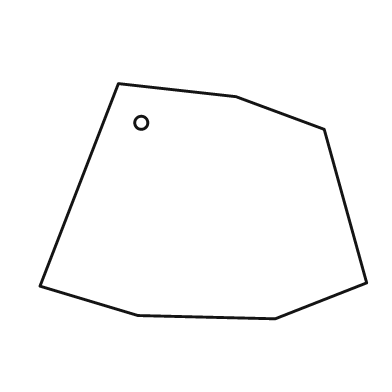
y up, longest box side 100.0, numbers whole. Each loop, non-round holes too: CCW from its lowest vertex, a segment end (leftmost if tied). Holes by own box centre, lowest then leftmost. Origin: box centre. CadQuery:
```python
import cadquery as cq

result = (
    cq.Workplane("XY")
    .moveTo(22.0, -36.0)
    .lineTo(50.0, -25.0)
    .lineTo(37.0, 22.0)
    .lineTo(10.0, 32.0)
    .lineTo(-26.0, 36.0)
    .lineTo(-50.0, -26.0)
    .lineTo(-20.0, -35.0)
    .close()
    .moveTo(-19.0, 24.0)
    .circle(2.0)
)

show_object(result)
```